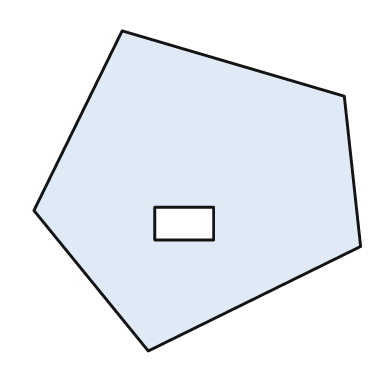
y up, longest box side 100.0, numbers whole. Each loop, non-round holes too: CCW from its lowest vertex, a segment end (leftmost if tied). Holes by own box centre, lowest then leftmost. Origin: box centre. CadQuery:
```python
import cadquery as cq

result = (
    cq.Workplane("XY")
    .moveTo(-15.0, -49.0)
    .lineTo(50.0, -17.0)
    .lineTo(45.0, 29.0)
    .lineTo(-23.0, 49.0)
    .lineTo(-50.0, -6.0)
    .close()
    .moveTo(-13.0, -15.0)
    .lineTo(5.0, -15.0)
    .lineTo(5.0, -5.0)
    .lineTo(-13.0, -5.0)
    .close()
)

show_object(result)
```